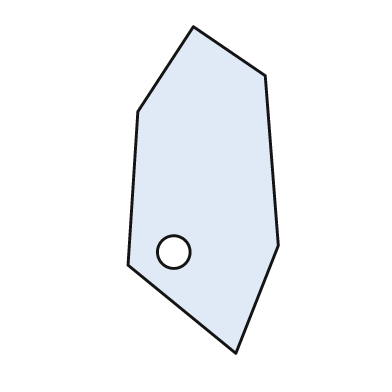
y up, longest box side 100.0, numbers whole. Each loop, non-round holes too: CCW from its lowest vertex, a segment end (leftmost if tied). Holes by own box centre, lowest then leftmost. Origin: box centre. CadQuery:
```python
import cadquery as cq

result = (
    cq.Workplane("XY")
    .moveTo(10.0, -50.0)
    .lineTo(23.0, -17.0)
    .lineTo(19.0, 35.0)
    .lineTo(-3.0, 50.0)
    .lineTo(-20.0, 24.0)
    .lineTo(-23.0, -23.0)
    .close()
    .moveTo(-9.0, -19.0)
    .circle(5.0)
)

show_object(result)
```